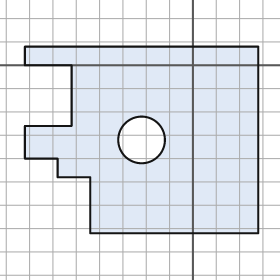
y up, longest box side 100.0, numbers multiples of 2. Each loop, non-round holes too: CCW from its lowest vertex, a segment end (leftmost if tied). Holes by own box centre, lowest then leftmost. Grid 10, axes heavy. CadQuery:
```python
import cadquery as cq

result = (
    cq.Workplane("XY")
    .moveTo(-44.0, -72.0)
    .lineTo(28.0, -72.0)
    .lineTo(28.0, 8.0)
    .lineTo(-72.0, 8.0)
    .lineTo(-72.0, 0.0)
    .lineTo(-52.0, 0.0)
    .lineTo(-52.0, -26.0)
    .lineTo(-72.0, -26.0)
    .lineTo(-72.0, -40.0)
    .lineTo(-58.0, -40.0)
    .lineTo(-58.0, -48.0)
    .lineTo(-44.0, -48.0)
    .close()
    .moveTo(-22.0, -32.0)
    .circle(10.0)
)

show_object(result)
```